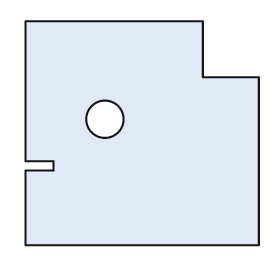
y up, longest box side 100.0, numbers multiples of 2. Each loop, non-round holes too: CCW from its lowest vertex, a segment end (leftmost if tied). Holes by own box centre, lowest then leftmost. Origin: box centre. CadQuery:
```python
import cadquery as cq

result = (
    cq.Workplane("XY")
    .moveTo(-50.0, -48.0)
    .lineTo(50.0, -48.0)
    .lineTo(50.0, 24.0)
    .lineTo(26.0, 24.0)
    .lineTo(26.0, 48.0)
    .lineTo(-50.0, 48.0)
    .lineTo(-50.0, -12.0)
    .lineTo(-38.0, -12.0)
    .lineTo(-38.0, -16.0)
    .lineTo(-50.0, -16.0)
    .close()
    .moveTo(-16.0, 6.0)
    .circle(8.0)
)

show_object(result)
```